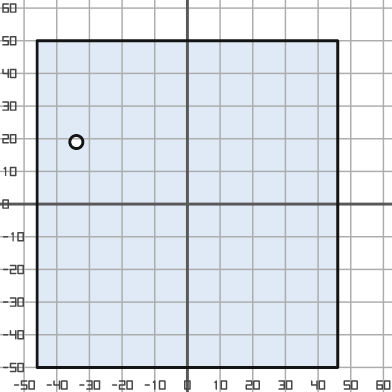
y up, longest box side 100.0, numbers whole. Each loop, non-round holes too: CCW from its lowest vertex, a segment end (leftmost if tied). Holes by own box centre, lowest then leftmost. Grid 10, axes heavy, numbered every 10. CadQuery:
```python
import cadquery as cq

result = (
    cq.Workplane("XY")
    .moveTo(-46.0, -50.0)
    .lineTo(46.0, -50.0)
    .lineTo(46.0, 50.0)
    .lineTo(-46.0, 50.0)
    .close()
    .moveTo(-34.0, 19.0)
    .circle(2.0)
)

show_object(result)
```